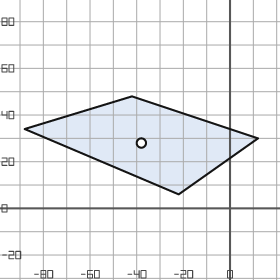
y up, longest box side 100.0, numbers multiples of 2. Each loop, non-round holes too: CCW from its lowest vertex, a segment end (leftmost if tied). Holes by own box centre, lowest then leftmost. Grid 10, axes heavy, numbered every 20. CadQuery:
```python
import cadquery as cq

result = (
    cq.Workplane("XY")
    .moveTo(-22.0, 6.0)
    .lineTo(12.0, 30.0)
    .lineTo(-42.0, 48.0)
    .lineTo(-88.0, 34.0)
    .close()
    .moveTo(-38.0, 28.0)
    .circle(2.0)
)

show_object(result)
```